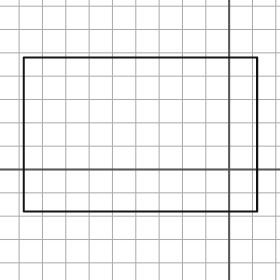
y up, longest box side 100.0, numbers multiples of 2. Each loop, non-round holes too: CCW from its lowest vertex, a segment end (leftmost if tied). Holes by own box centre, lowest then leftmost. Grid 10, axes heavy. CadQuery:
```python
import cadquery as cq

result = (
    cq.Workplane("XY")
    .moveTo(-88.0, -18.0)
    .lineTo(12.0, -18.0)
    .lineTo(12.0, 48.0)
    .lineTo(-88.0, 48.0)
    .close()
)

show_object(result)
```